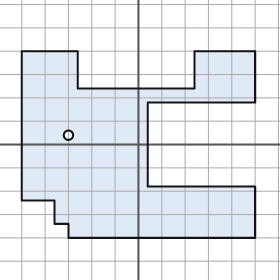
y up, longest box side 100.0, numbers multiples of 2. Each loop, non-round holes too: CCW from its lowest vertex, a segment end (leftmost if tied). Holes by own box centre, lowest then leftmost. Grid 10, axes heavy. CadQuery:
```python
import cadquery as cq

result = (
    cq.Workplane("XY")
    .moveTo(-30.0, -40.0)
    .lineTo(50.0, -40.0)
    .lineTo(50.0, -18.0)
    .lineTo(4.0, -18.0)
    .lineTo(4.0, 18.0)
    .lineTo(50.0, 18.0)
    .lineTo(50.0, 40.0)
    .lineTo(24.0, 40.0)
    .lineTo(24.0, 24.0)
    .lineTo(-26.0, 24.0)
    .lineTo(-26.0, 40.0)
    .lineTo(-50.0, 40.0)
    .lineTo(-50.0, -24.0)
    .lineTo(-36.0, -24.0)
    .lineTo(-36.0, -34.0)
    .lineTo(-30.0, -34.0)
    .close()
    .moveTo(-30.0, 4.0)
    .circle(2.0)
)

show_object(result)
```